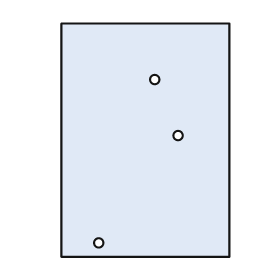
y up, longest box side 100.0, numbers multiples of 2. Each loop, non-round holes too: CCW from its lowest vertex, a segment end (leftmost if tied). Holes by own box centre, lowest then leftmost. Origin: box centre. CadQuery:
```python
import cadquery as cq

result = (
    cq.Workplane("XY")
    .moveTo(-36.0, -50.0)
    .lineTo(36.0, -50.0)
    .lineTo(36.0, 50.0)
    .lineTo(-36.0, 50.0)
    .close()
    .moveTo(-20.0, -44.0)
    .circle(2.0)
    .moveTo(14.0, 2.0)
    .circle(2.0)
    .moveTo(4.0, 26.0)
    .circle(2.0)
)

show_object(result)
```